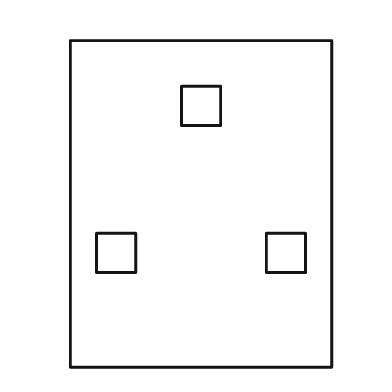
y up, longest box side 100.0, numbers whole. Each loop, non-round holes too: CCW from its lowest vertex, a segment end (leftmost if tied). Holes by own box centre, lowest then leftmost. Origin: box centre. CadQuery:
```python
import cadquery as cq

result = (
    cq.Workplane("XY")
    .moveTo(-40.0, -50.0)
    .lineTo(40.0, -50.0)
    .lineTo(40.0, 50.0)
    .lineTo(-40.0, 50.0)
    .close()
    .moveTo(-32.0, -21.0)
    .lineTo(-20.0, -21.0)
    .lineTo(-20.0, -9.0)
    .lineTo(-32.0, -9.0)
    .close()
    .moveTo(20.0, -21.0)
    .lineTo(32.0, -21.0)
    .lineTo(32.0, -9.0)
    .lineTo(20.0, -9.0)
    .close()
    .moveTo(-6.0, 24.0)
    .lineTo(6.0, 24.0)
    .lineTo(6.0, 36.0)
    .lineTo(-6.0, 36.0)
    .close()
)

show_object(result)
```